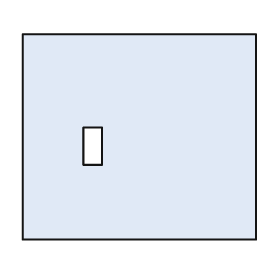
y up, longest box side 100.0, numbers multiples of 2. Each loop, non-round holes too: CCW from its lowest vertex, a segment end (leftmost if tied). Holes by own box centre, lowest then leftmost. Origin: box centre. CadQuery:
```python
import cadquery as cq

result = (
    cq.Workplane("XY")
    .moveTo(-50.0, -44.0)
    .lineTo(50.0, -44.0)
    .lineTo(50.0, 44.0)
    .lineTo(-50.0, 44.0)
    .close()
    .moveTo(-24.0, -12.0)
    .lineTo(-16.0, -12.0)
    .lineTo(-16.0, 4.0)
    .lineTo(-24.0, 4.0)
    .close()
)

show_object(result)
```